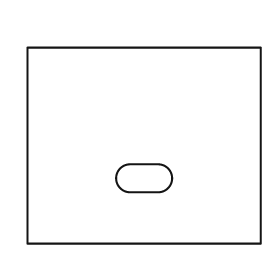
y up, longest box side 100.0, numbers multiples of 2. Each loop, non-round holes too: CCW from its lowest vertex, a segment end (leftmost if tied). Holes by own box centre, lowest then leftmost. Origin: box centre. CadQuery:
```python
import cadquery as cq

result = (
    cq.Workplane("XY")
    .moveTo(-50.0, -42.0)
    .lineTo(50.0, -42.0)
    .lineTo(50.0, 42.0)
    .lineTo(-50.0, 42.0)
    .close()
    .moveTo(-6.0, -20.0)
    .lineTo(6.0, -20.0)
    .threePointArc((12.0, -14.0), (6.0, -8.0))
    .lineTo(-6.0, -8.0)
    .threePointArc((-12.0, -14.0), (-6.0, -20.0))
    .close()
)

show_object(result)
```